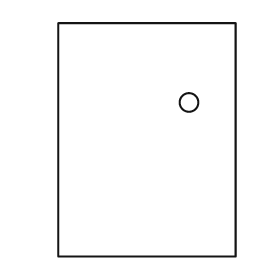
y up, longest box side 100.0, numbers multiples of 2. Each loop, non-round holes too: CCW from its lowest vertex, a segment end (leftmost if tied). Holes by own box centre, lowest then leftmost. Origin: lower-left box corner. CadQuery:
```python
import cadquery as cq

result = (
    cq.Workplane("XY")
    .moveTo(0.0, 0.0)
    .lineTo(76.0, 0.0)
    .lineTo(76.0, 100.0)
    .lineTo(0.0, 100.0)
    .close()
    .moveTo(56.0, 66.0)
    .circle(4.0)
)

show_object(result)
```